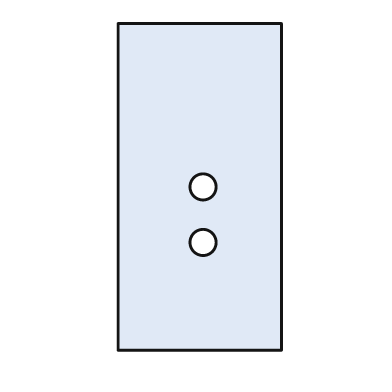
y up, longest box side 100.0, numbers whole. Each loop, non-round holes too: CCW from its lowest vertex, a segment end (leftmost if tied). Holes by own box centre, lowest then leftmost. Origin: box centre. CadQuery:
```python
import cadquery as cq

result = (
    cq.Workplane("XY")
    .moveTo(-25.0, -50.0)
    .lineTo(25.0, -50.0)
    .lineTo(25.0, 50.0)
    .lineTo(-25.0, 50.0)
    .close()
    .moveTo(1.0, -17.0)
    .circle(4.0)
    .moveTo(1.0, 0.0)
    .circle(4.0)
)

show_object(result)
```